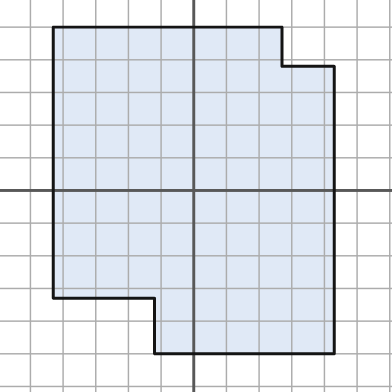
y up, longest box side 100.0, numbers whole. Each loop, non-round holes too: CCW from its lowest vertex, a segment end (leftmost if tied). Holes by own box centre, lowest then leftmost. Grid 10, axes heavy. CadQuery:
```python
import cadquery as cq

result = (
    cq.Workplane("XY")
    .moveTo(-12.0, -50.0)
    .lineTo(43.0, -50.0)
    .lineTo(43.0, 38.0)
    .lineTo(27.0, 38.0)
    .lineTo(27.0, 50.0)
    .lineTo(-43.0, 50.0)
    .lineTo(-43.0, -33.0)
    .lineTo(-12.0, -33.0)
    .close()
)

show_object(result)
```